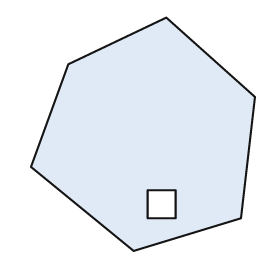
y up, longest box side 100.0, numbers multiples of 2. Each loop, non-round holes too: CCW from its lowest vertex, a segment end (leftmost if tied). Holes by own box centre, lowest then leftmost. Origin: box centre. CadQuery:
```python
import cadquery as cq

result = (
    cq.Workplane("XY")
    .moveTo(-4.0, -50.0)
    .lineTo(42.0, -36.0)
    .lineTo(48.0, 16.0)
    .lineTo(10.0, 50.0)
    .lineTo(-32.0, 30.0)
    .lineTo(-48.0, -14.0)
    .close()
    .moveTo(2.0, -36.0)
    .lineTo(14.0, -36.0)
    .lineTo(14.0, -24.0)
    .lineTo(2.0, -24.0)
    .close()
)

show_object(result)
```